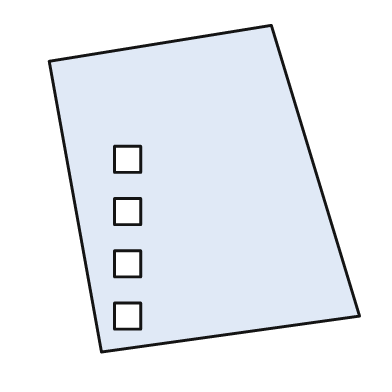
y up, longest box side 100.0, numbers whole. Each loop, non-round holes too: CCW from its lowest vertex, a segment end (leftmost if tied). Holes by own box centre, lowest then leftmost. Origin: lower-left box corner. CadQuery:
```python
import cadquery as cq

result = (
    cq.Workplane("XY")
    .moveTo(16.0, 0.0)
    .lineTo(95.0, 11.0)
    .lineTo(68.0, 100.0)
    .lineTo(0.0, 89.0)
    .close()
    .moveTo(20.0, 7.0)
    .lineTo(28.0, 7.0)
    .lineTo(28.0, 15.0)
    .lineTo(20.0, 15.0)
    .close()
    .moveTo(20.0, 23.0)
    .lineTo(28.0, 23.0)
    .lineTo(28.0, 31.0)
    .lineTo(20.0, 31.0)
    .close()
    .moveTo(20.0, 39.0)
    .lineTo(28.0, 39.0)
    .lineTo(28.0, 47.0)
    .lineTo(20.0, 47.0)
    .close()
    .moveTo(20.0, 55.0)
    .lineTo(28.0, 55.0)
    .lineTo(28.0, 63.0)
    .lineTo(20.0, 63.0)
    .close()
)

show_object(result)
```